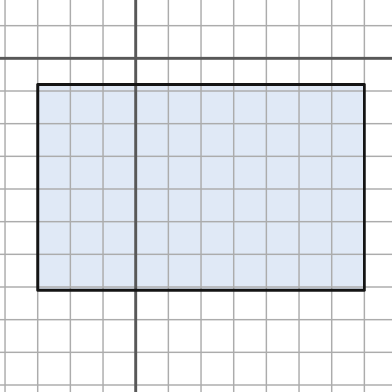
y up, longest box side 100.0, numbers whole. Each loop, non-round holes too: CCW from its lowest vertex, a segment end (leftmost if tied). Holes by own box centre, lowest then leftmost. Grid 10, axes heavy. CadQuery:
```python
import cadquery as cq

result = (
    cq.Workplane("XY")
    .moveTo(-30.0, -71.0)
    .lineTo(70.0, -71.0)
    .lineTo(70.0, -8.0)
    .lineTo(-30.0, -8.0)
    .close()
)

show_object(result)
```